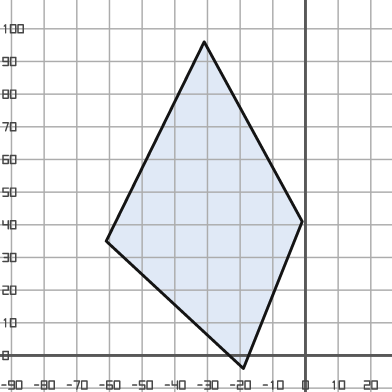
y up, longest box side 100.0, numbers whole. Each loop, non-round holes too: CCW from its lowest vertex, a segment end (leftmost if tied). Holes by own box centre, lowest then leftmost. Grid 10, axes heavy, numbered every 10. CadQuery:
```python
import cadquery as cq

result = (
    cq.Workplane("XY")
    .moveTo(-19.0, -4.0)
    .lineTo(-1.0, 41.0)
    .lineTo(-31.0, 96.0)
    .lineTo(-61.0, 35.0)
    .close()
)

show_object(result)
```